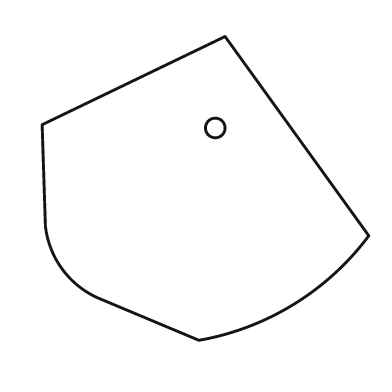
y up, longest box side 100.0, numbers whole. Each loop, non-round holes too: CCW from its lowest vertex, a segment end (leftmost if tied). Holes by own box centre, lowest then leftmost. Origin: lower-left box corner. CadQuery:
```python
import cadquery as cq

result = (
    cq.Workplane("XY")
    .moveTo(48.0, 0.0)
    .threePointArc((77.0, 11.0), (100.0, 32.0))
    .lineTo(56.0, 93.0)
    .lineTo(0.0, 66.0)
    .lineTo(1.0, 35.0)
    .threePointArc((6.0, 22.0), (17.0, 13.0))
    .close()
    .moveTo(53.0, 65.0)
    .circle(3.0)
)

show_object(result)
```